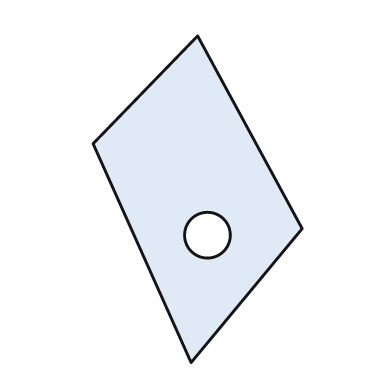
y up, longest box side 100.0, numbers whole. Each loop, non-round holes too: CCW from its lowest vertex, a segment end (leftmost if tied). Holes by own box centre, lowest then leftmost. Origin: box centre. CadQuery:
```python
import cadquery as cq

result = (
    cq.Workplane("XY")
    .moveTo(-2.0, -50.0)
    .lineTo(32.0, -9.0)
    .lineTo(0.0, 50.0)
    .lineTo(-32.0, 17.0)
    .close()
    .moveTo(3.0, -11.0)
    .circle(7.0)
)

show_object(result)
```